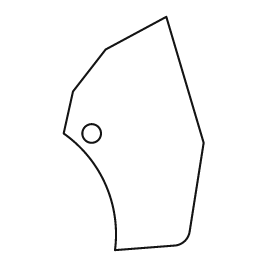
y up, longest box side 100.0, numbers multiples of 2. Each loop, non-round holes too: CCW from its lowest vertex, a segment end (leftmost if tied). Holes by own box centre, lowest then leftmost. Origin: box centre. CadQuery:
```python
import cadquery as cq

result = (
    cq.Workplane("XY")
    .moveTo(-8.0, -50.0)
    .lineTo(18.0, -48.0)
    .threePointArc((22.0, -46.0), (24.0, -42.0))
    .lineTo(30.0, -4.0)
    .lineTo(14.0, 50.0)
    .lineTo(-12.0, 36.0)
    .lineTo(-26.0, 18.0)
    .lineTo(-30.0, 0.0)
    .threePointArc((-12.0, -22.0), (-8.0, -50.0))
    .close()
    .moveTo(-18.0, 0.0)
    .circle(4.0)
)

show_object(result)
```